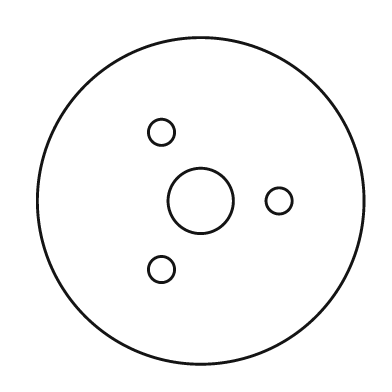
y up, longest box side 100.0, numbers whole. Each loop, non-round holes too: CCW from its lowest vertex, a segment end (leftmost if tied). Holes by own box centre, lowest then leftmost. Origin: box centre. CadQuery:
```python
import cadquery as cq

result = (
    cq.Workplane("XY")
    .moveTo(0.0, 0.0)
    .circle(50.0)
    .moveTo(-12.0, -21.0)
    .circle(4.0)
    .moveTo(0.0, 0.0)
    .circle(10.0)
    .moveTo(24.0, 0.0)
    .circle(4.0)
    .moveTo(-12.0, 21.0)
    .circle(4.0)
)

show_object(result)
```